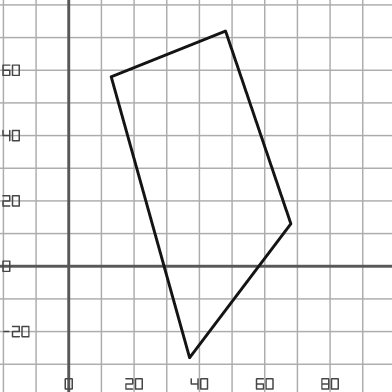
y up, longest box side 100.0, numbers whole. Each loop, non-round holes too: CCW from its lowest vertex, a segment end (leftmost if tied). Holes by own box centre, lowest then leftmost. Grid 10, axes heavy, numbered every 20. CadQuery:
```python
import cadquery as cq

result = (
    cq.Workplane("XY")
    .moveTo(37.0, -28.0)
    .lineTo(68.0, 13.0)
    .lineTo(48.0, 72.0)
    .lineTo(13.0, 58.0)
    .close()
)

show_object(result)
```